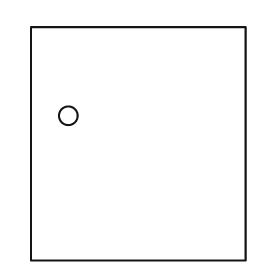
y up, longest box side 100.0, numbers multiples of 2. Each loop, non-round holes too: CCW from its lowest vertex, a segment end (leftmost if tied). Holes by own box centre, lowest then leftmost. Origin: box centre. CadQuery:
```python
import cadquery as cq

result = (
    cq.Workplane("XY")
    .moveTo(-46.0, -50.0)
    .lineTo(46.0, -50.0)
    .lineTo(46.0, 50.0)
    .lineTo(-46.0, 50.0)
    .close()
    .moveTo(-30.0, 12.0)
    .circle(4.0)
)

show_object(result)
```